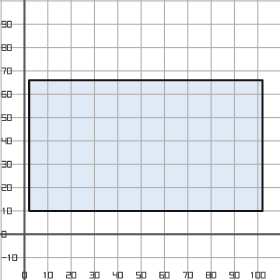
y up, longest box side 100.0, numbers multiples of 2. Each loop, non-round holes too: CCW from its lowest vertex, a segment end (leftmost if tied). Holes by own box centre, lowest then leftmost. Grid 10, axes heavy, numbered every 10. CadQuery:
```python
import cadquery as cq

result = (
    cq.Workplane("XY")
    .moveTo(2.0, 10.0)
    .lineTo(102.0, 10.0)
    .lineTo(102.0, 66.0)
    .lineTo(2.0, 66.0)
    .close()
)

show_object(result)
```